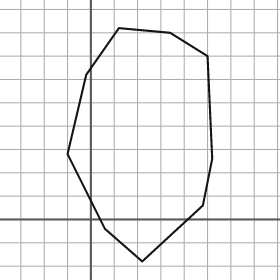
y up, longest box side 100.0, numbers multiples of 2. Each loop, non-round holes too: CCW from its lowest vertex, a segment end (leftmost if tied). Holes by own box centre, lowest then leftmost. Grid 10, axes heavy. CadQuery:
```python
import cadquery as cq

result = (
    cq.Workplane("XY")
    .moveTo(22.0, -18.0)
    .lineTo(48.0, 6.0)
    .lineTo(52.0, 26.0)
    .lineTo(50.0, 70.0)
    .lineTo(34.0, 80.0)
    .lineTo(12.0, 82.0)
    .lineTo(-2.0, 62.0)
    .lineTo(-10.0, 28.0)
    .lineTo(6.0, -4.0)
    .close()
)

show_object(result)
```